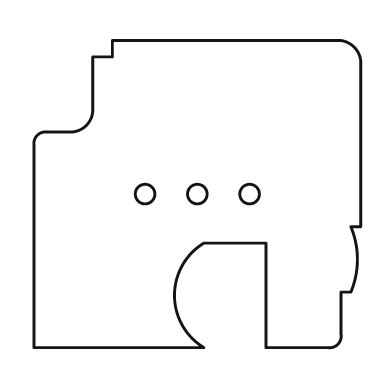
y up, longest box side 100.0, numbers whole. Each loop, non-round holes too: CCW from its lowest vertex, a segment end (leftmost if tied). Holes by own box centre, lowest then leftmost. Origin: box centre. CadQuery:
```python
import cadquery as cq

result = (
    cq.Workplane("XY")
    .moveTo(-50.0, -47.0)
    .lineTo(2.0, -47.0)
    .threePointArc((-7.0, -31.0), (2.0, -15.0))
    .lineTo(21.0, -15.0)
    .lineTo(21.0, -47.0)
    .lineTo(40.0, -47.0)
    .threePointArc((43.0, -46.0), (44.0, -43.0))
    .lineTo(44.0, -30.0)
    .lineTo(47.0, -30.0)
    .threePointArc((49.0, -20.0), (47.0, -10.0))
    .lineTo(50.0, -10.0)
    .lineTo(50.0, 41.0)
    .threePointArc((48.0, 45.0), (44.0, 47.0))
    .lineTo(-26.0, 47.0)
    .lineTo(-26.0, 42.0)
    .lineTo(-32.0, 42.0)
    .lineTo(-32.0, 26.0)
    .threePointArc((-34.0, 21.0), (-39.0, 19.0))
    .lineTo(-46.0, 19.0)
    .threePointArc((-49.0, 18.0), (-50.0, 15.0))
    .close()
    .moveTo(-16.0, 0.0)
    .circle(3.0)
    .moveTo(0.0, 0.0)
    .circle(3.0)
    .moveTo(16.0, 0.0)
    .circle(3.0)
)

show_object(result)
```